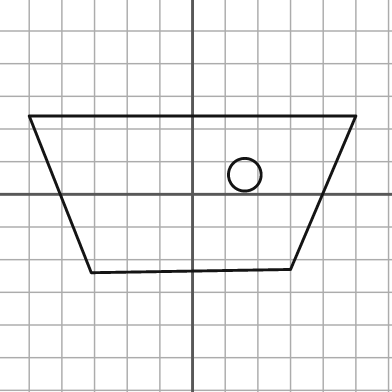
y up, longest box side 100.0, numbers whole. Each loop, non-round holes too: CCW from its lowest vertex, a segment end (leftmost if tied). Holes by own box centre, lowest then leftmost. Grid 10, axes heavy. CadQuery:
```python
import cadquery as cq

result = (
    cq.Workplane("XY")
    .moveTo(-31.0, -24.0)
    .lineTo(30.0, -23.0)
    .lineTo(50.0, 24.0)
    .lineTo(-50.0, 24.0)
    .close()
    .moveTo(16.0, 6.0)
    .circle(5.0)
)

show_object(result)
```